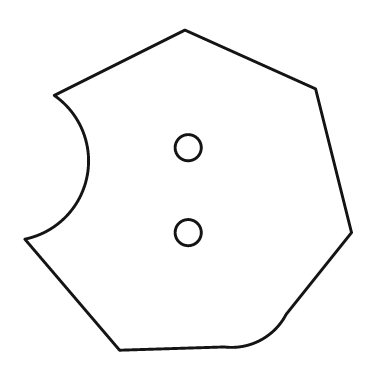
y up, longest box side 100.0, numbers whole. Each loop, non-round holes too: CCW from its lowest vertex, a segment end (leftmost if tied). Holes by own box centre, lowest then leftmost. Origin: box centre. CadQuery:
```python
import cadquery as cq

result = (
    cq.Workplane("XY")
    .moveTo(-21.0, -49.0)
    .lineTo(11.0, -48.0)
    .threePointArc((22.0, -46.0), (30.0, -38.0))
    .lineTo(50.0, -13.0)
    .lineTo(39.0, 31.0)
    .lineTo(-1.0, 49.0)
    .lineTo(-41.0, 29.0)
    .threePointArc((-31.0, 4.0), (-50.0, -15.0))
    .close()
    .moveTo(0.0, -13.0)
    .circle(4.0)
    .moveTo(0.0, 13.0)
    .circle(4.0)
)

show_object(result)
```